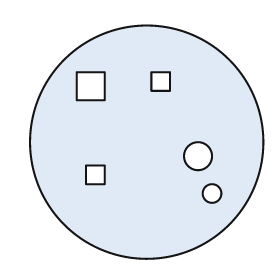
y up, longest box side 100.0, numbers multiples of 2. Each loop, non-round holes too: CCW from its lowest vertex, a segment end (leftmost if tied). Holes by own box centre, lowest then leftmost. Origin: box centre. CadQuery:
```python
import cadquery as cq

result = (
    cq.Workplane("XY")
    .moveTo(0.0, 0.0)
    .circle(50.0)
    .moveTo(28.0, -22.0)
    .circle(4.0)
    .moveTo(-26.0, -18.0)
    .lineTo(-18.0, -18.0)
    .lineTo(-18.0, -10.0)
    .lineTo(-26.0, -10.0)
    .close()
    .moveTo(22.0, -6.0)
    .circle(6.0)
    .moveTo(-30.0, 18.0)
    .lineTo(-18.0, 18.0)
    .lineTo(-18.0, 30.0)
    .lineTo(-30.0, 30.0)
    .close()
    .moveTo(2.0, 22.0)
    .lineTo(10.0, 22.0)
    .lineTo(10.0, 30.0)
    .lineTo(2.0, 30.0)
    .close()
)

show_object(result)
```